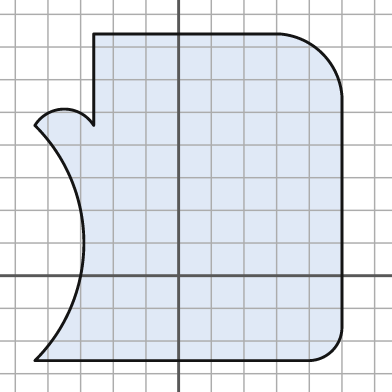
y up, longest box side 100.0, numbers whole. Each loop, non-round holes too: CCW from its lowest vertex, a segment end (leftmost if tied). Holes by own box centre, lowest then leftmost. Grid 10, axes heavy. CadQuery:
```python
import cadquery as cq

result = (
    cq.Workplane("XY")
    .moveTo(-44.0, -26.0)
    .lineTo(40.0, -26.0)
    .threePointArc((47.0, -23.0), (50.0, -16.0))
    .lineTo(50.0, 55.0)
    .threePointArc((44.0, 68.0), (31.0, 74.0))
    .lineTo(-26.0, 74.0)
    .lineTo(-26.0, 46.0)
    .threePointArc((-35.0, 51.0), (-44.0, 46.0))
    .threePointArc((-29.0, 10.0), (-44.0, -26.0))
    .close()
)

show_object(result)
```